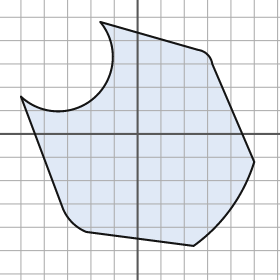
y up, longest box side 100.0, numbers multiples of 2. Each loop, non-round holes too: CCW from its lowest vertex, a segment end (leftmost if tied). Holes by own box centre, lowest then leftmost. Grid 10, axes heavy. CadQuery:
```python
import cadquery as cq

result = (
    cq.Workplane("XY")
    .moveTo(24.0, -48.0)
    .threePointArc((40.0, -32.0), (50.0, -12.0))
    .lineTo(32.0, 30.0)
    .threePointArc((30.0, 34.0), (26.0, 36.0))
    .lineTo(-16.0, 48.0)
    .threePointArc((-18.0, 16.0), (-50.0, 16.0))
    .lineTo(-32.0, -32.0)
    .threePointArc((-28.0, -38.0), (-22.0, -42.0))
    .close()
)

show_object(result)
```